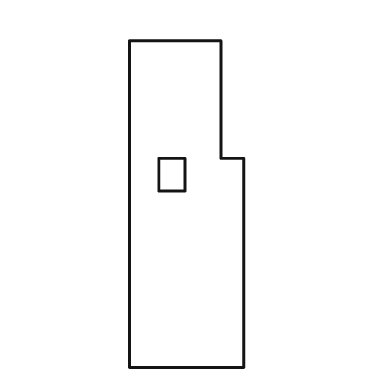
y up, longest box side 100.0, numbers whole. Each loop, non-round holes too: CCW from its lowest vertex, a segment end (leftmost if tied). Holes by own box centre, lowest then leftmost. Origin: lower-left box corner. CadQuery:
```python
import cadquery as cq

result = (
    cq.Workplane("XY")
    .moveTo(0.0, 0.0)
    .lineTo(35.0, 0.0)
    .lineTo(35.0, 64.0)
    .lineTo(28.0, 64.0)
    .lineTo(28.0, 100.0)
    .lineTo(0.0, 100.0)
    .close()
    .moveTo(9.0, 54.0)
    .lineTo(17.0, 54.0)
    .lineTo(17.0, 64.0)
    .lineTo(9.0, 64.0)
    .close()
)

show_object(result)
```